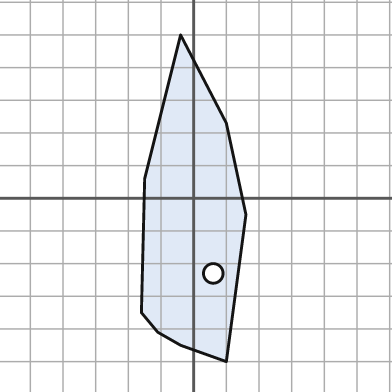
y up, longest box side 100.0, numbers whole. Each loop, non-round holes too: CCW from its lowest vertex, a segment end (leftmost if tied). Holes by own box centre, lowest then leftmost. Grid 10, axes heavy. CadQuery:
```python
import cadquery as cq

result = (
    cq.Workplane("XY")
    .moveTo(10.0, -50.0)
    .lineTo(16.0, -5.0)
    .lineTo(10.0, 23.0)
    .lineTo(-4.0, 50.0)
    .lineTo(-15.0, 6.0)
    .lineTo(-16.0, -35.0)
    .lineTo(-11.0, -41.0)
    .lineTo(-4.0, -45.0)
    .close()
    .moveTo(6.0, -23.0)
    .circle(3.0)
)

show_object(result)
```